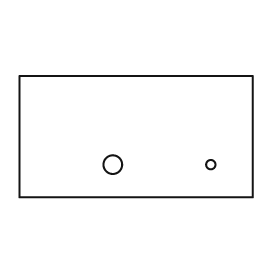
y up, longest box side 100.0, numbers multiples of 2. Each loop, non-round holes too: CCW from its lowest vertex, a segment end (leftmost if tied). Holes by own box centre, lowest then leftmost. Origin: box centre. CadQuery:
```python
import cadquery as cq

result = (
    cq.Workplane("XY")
    .moveTo(-50.0, -26.0)
    .lineTo(50.0, -26.0)
    .lineTo(50.0, 26.0)
    .lineTo(-50.0, 26.0)
    .close()
    .moveTo(-10.0, -12.0)
    .circle(4.0)
    .moveTo(32.0, -12.0)
    .circle(2.0)
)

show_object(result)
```